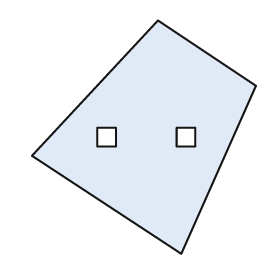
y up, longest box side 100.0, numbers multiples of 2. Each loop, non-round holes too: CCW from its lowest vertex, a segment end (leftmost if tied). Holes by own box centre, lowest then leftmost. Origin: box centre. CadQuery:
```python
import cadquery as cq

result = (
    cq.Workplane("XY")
    .moveTo(16.0, -50.0)
    .lineTo(48.0, 22.0)
    .lineTo(6.0, 50.0)
    .lineTo(-48.0, -8.0)
    .close()
    .moveTo(-20.0, -4.0)
    .lineTo(-12.0, -4.0)
    .lineTo(-12.0, 4.0)
    .lineTo(-20.0, 4.0)
    .close()
    .moveTo(14.0, -4.0)
    .lineTo(22.0, -4.0)
    .lineTo(22.0, 4.0)
    .lineTo(14.0, 4.0)
    .close()
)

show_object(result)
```